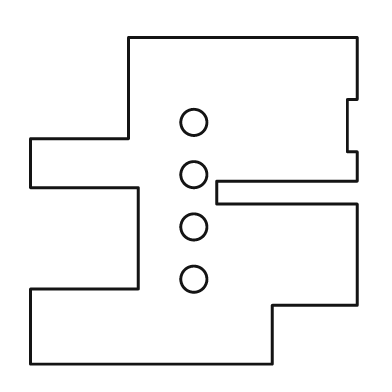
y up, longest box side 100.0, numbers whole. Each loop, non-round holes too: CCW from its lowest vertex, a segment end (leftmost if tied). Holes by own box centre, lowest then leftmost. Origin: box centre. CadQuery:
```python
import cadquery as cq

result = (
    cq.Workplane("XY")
    .moveTo(-50.0, -50.0)
    .lineTo(24.0, -50.0)
    .lineTo(24.0, -32.0)
    .lineTo(50.0, -32.0)
    .lineTo(50.0, -1.0)
    .lineTo(7.0, -1.0)
    .lineTo(7.0, 6.0)
    .lineTo(50.0, 6.0)
    .lineTo(50.0, 15.0)
    .lineTo(47.0, 15.0)
    .lineTo(47.0, 31.0)
    .lineTo(50.0, 31.0)
    .lineTo(50.0, 50.0)
    .lineTo(-20.0, 50.0)
    .lineTo(-20.0, 19.0)
    .lineTo(-50.0, 19.0)
    .lineTo(-50.0, 4.0)
    .lineTo(-17.0, 4.0)
    .lineTo(-17.0, -27.0)
    .lineTo(-50.0, -27.0)
    .close()
    .moveTo(0.0, -24.0)
    .circle(4.0)
    .moveTo(0.0, -8.0)
    .circle(4.0)
    .moveTo(0.0, 8.0)
    .circle(4.0)
    .moveTo(0.0, 24.0)
    .circle(4.0)
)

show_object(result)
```